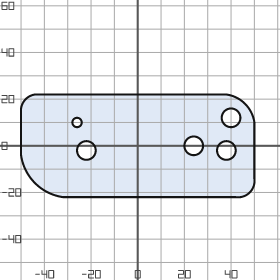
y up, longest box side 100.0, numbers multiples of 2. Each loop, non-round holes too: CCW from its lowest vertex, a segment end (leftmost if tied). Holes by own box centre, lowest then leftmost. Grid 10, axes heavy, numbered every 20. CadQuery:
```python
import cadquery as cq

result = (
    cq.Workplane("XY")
    .moveTo(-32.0, -22.0)
    .lineTo(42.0, -22.0)
    .threePointArc((48.0, -20.0), (50.0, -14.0))
    .lineTo(50.0, 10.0)
    .threePointArc((46.0, 18.0), (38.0, 22.0))
    .lineTo(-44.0, 22.0)
    .threePointArc((-48.0, 20.0), (-50.0, 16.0))
    .lineTo(-50.0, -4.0)
    .threePointArc((-44.0, -16.0), (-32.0, -22.0))
    .close()
    .moveTo(-22.0, -2.0)
    .circle(4.0)
    .moveTo(38.0, -2.0)
    .circle(4.0)
    .moveTo(24.0, 0.0)
    .circle(4.0)
    .moveTo(-26.0, 10.0)
    .circle(2.0)
    .moveTo(40.0, 12.0)
    .circle(4.0)
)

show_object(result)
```